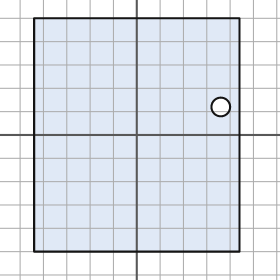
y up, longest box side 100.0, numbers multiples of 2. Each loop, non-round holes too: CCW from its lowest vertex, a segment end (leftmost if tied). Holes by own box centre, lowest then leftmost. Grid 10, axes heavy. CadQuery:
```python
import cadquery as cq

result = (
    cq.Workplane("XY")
    .moveTo(-44.0, -50.0)
    .lineTo(44.0, -50.0)
    .lineTo(44.0, 50.0)
    .lineTo(-44.0, 50.0)
    .close()
    .moveTo(36.0, 12.0)
    .circle(4.0)
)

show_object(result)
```